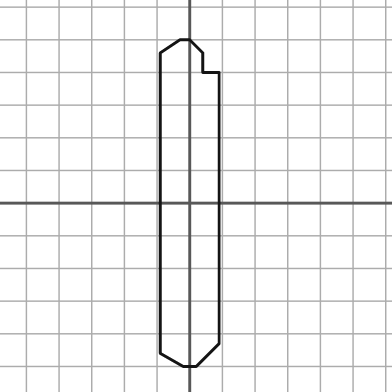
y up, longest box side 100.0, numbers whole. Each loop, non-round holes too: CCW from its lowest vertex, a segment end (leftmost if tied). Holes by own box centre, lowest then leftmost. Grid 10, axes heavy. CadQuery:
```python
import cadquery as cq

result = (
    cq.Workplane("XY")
    .moveTo(-2.0, -50.0)
    .lineTo(2.0, -50.0)
    .lineTo(9.0, -43.0)
    .lineTo(9.0, 40.0)
    .lineTo(4.0, 40.0)
    .lineTo(4.0, 46.0)
    .lineTo(0.0, 50.0)
    .lineTo(-3.0, 50.0)
    .lineTo(-9.0, 46.0)
    .lineTo(-9.0, -46.0)
    .close()
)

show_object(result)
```